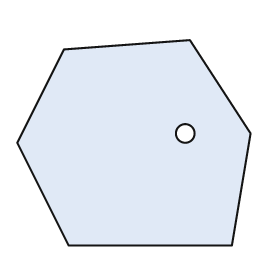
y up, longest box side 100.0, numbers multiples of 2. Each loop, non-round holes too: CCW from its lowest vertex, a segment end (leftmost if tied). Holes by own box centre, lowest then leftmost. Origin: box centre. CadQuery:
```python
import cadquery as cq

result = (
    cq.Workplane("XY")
    .moveTo(-28.0, -44.0)
    .lineTo(42.0, -44.0)
    .lineTo(50.0, 4.0)
    .lineTo(24.0, 44.0)
    .lineTo(-30.0, 40.0)
    .lineTo(-50.0, 0.0)
    .close()
    .moveTo(22.0, 4.0)
    .circle(4.0)
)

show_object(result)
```